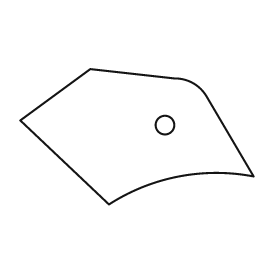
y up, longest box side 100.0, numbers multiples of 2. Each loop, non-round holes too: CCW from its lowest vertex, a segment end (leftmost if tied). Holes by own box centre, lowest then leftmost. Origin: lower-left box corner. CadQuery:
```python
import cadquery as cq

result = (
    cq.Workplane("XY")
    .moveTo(38.0, 0.0)
    .threePointArc((68.0, 12.0), (100.0, 12.0))
    .lineTo(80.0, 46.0)
    .threePointArc((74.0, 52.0), (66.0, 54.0))
    .lineTo(30.0, 58.0)
    .lineTo(0.0, 36.0)
    .close()
    .moveTo(62.0, 34.0)
    .circle(4.0)
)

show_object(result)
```